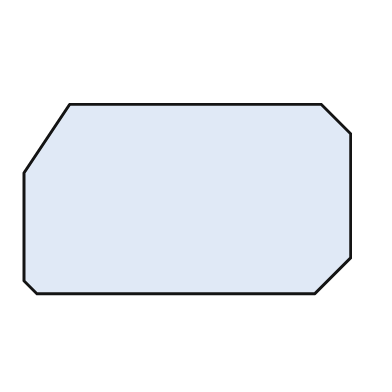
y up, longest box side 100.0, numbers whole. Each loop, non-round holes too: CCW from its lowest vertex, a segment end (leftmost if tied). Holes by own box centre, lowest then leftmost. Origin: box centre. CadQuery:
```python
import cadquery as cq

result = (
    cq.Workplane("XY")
    .moveTo(-46.0, -29.0)
    .lineTo(39.0, -29.0)
    .lineTo(50.0, -18.0)
    .lineTo(50.0, 20.0)
    .lineTo(41.0, 29.0)
    .lineTo(-36.0, 29.0)
    .lineTo(-50.0, 8.0)
    .lineTo(-50.0, -25.0)
    .close()
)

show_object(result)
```